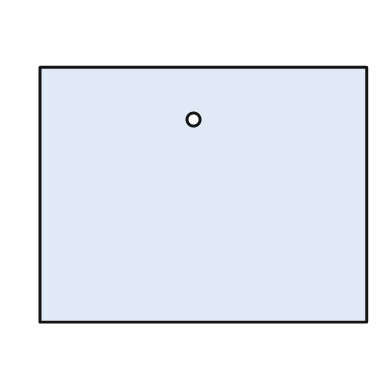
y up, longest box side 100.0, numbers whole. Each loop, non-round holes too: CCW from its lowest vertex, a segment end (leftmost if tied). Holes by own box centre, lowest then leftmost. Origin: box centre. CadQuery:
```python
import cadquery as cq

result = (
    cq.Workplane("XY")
    .moveTo(-50.0, -39.0)
    .lineTo(50.0, -39.0)
    .lineTo(50.0, 39.0)
    .lineTo(-50.0, 39.0)
    .close()
    .moveTo(-3.0, 23.0)
    .circle(2.0)
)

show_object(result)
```